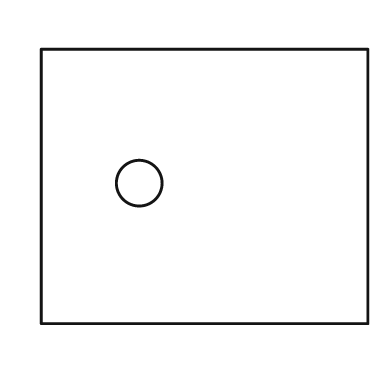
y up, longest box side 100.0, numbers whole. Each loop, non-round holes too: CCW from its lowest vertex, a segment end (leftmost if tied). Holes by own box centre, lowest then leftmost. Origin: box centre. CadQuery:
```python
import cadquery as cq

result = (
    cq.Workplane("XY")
    .moveTo(-50.0, -42.0)
    .lineTo(50.0, -42.0)
    .lineTo(50.0, 42.0)
    .lineTo(-50.0, 42.0)
    .close()
    .moveTo(-20.0, 1.0)
    .circle(7.0)
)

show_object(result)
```